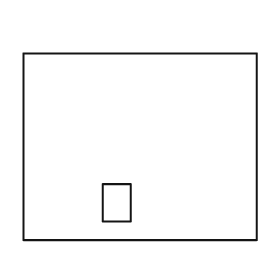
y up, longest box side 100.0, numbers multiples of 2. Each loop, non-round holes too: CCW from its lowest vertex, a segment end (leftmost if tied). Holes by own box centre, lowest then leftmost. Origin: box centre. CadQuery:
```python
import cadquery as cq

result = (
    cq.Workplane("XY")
    .moveTo(-50.0, -40.0)
    .lineTo(50.0, -40.0)
    .lineTo(50.0, 40.0)
    .lineTo(-50.0, 40.0)
    .close()
    .moveTo(-16.0, -32.0)
    .lineTo(-4.0, -32.0)
    .lineTo(-4.0, -16.0)
    .lineTo(-16.0, -16.0)
    .close()
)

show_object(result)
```